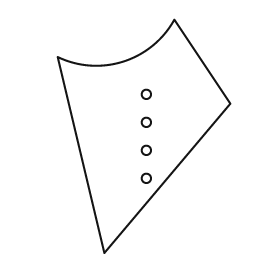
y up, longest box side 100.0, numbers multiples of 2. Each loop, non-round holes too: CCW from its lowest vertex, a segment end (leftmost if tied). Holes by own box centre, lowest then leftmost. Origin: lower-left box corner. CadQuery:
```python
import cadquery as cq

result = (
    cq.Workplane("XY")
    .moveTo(20.0, 0.0)
    .lineTo(74.0, 64.0)
    .lineTo(50.0, 100.0)
    .threePointArc((28.0, 82.0), (0.0, 84.0))
    .close()
    .moveTo(38.0, 32.0)
    .circle(2.0)
    .moveTo(38.0, 44.0)
    .circle(2.0)
    .moveTo(38.0, 56.0)
    .circle(2.0)
    .moveTo(38.0, 68.0)
    .circle(2.0)
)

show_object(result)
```